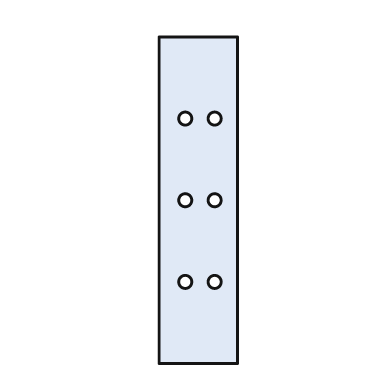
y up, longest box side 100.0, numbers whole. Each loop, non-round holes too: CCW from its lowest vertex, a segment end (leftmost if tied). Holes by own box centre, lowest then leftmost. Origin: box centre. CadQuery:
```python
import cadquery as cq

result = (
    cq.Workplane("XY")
    .moveTo(-12.0, -50.0)
    .lineTo(12.0, -50.0)
    .lineTo(12.0, 50.0)
    .lineTo(-12.0, 50.0)
    .close()
    .moveTo(-4.0, -25.0)
    .circle(2.0)
    .moveTo(5.0, -25.0)
    .circle(2.0)
    .moveTo(-4.0, 0.0)
    .circle(2.0)
    .moveTo(5.0, 0.0)
    .circle(2.0)
    .moveTo(-4.0, 25.0)
    .circle(2.0)
    .moveTo(5.0, 25.0)
    .circle(2.0)
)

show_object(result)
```